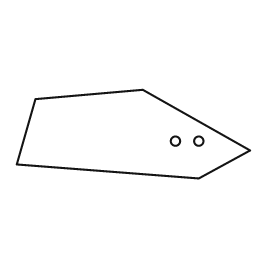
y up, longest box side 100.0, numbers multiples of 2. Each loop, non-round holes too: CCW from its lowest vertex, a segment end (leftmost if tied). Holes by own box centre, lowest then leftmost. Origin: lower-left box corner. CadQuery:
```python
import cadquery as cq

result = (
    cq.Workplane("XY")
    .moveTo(78.0, 0.0)
    .lineTo(100.0, 12.0)
    .lineTo(54.0, 38.0)
    .lineTo(8.0, 34.0)
    .lineTo(0.0, 6.0)
    .close()
    .moveTo(68.0, 16.0)
    .circle(2.0)
    .moveTo(78.0, 16.0)
    .circle(2.0)
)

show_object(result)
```